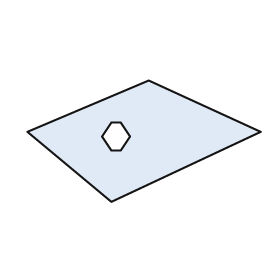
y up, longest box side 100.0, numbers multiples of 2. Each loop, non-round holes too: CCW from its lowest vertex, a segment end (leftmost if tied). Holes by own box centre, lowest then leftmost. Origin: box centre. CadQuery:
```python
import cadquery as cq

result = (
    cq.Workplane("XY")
    .moveTo(-14.0, -26.0)
    .lineTo(50.0, 4.0)
    .lineTo(2.0, 26.0)
    .lineTo(-50.0, 4.0)
    .close()
    .moveTo(-14.0, -4.0)
    .lineTo(-10.0, -4.0)
    .lineTo(-6.0, 2.0)
    .lineTo(-10.0, 8.0)
    .lineTo(-14.0, 8.0)
    .lineTo(-18.0, 2.0)
    .close()
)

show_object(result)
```